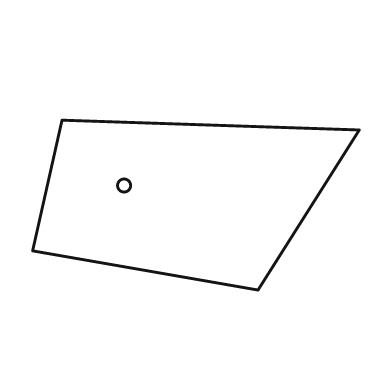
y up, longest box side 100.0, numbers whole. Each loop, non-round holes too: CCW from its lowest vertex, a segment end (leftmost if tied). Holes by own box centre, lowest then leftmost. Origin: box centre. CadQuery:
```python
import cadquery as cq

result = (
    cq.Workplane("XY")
    .moveTo(19.0, -26.0)
    .lineTo(50.0, 23.0)
    .lineTo(-41.0, 26.0)
    .lineTo(-50.0, -14.0)
    .close()
    .moveTo(-22.0, 6.0)
    .circle(2.0)
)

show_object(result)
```